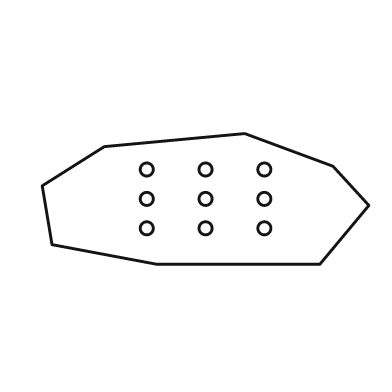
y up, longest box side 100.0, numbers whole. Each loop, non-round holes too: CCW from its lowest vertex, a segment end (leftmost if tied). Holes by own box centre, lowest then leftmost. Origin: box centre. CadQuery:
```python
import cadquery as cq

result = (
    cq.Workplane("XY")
    .moveTo(-15.0, -20.0)
    .lineTo(35.0, -20.0)
    .lineTo(50.0, -2.0)
    .lineTo(39.0, 10.0)
    .lineTo(12.0, 20.0)
    .lineTo(-31.0, 16.0)
    .lineTo(-50.0, 4.0)
    .lineTo(-47.0, -14.0)
    .close()
    .moveTo(-18.0, -9.0)
    .circle(2.0)
    .moveTo(0.0, -9.0)
    .circle(2.0)
    .moveTo(18.0, -9.0)
    .circle(2.0)
    .moveTo(-18.0, 0.0)
    .circle(2.0)
    .moveTo(0.0, 0.0)
    .circle(2.0)
    .moveTo(18.0, 0.0)
    .circle(2.0)
    .moveTo(-18.0, 9.0)
    .circle(2.0)
    .moveTo(0.0, 9.0)
    .circle(2.0)
    .moveTo(18.0, 9.0)
    .circle(2.0)
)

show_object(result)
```